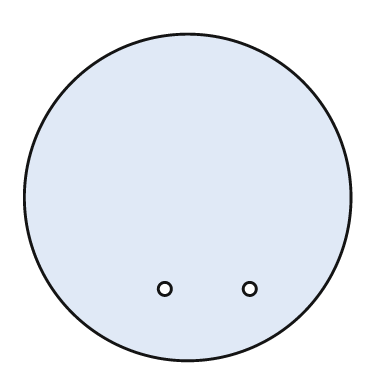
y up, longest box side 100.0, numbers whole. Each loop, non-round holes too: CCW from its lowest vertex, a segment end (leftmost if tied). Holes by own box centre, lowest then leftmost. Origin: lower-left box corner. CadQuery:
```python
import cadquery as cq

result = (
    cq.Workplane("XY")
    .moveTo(50.0, 50.0)
    .circle(50.0)
    .moveTo(43.0, 22.0)
    .circle(2.0)
    .moveTo(69.0, 22.0)
    .circle(2.0)
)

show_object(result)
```